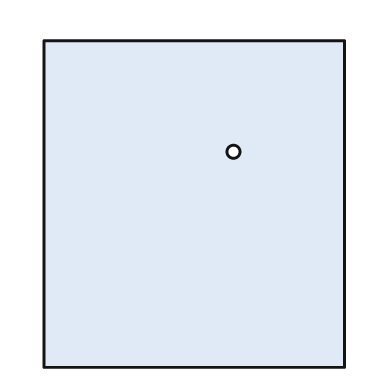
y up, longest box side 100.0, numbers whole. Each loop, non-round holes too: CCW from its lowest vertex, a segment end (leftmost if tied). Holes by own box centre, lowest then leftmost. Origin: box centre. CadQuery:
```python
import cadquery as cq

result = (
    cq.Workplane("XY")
    .moveTo(-46.0, -50.0)
    .lineTo(46.0, -50.0)
    .lineTo(46.0, 50.0)
    .lineTo(-46.0, 50.0)
    .close()
    .moveTo(12.0, 16.0)
    .circle(2.0)
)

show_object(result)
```